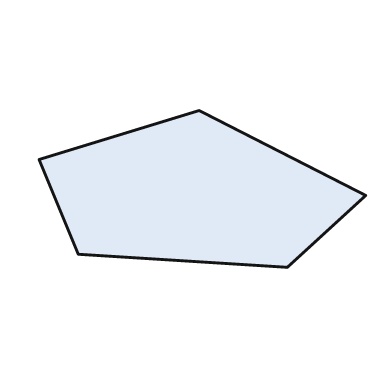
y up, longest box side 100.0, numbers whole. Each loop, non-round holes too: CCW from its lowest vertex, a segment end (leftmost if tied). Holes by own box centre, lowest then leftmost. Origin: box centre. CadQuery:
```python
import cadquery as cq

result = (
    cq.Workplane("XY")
    .moveTo(26.0, -24.0)
    .lineTo(50.0, -2.0)
    .lineTo(-1.0, 24.0)
    .lineTo(-50.0, 9.0)
    .lineTo(-38.0, -20.0)
    .close()
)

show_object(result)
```